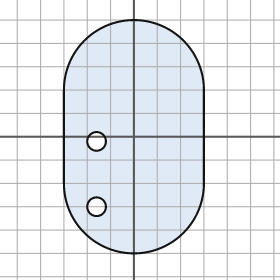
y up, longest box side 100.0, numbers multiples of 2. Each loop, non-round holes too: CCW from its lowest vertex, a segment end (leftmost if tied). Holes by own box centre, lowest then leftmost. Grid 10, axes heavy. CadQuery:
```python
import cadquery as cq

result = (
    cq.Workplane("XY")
    .moveTo(-30.0, -20.0)
    .threePointArc((0.0, -50.0), (30.0, -20.0))
    .lineTo(30.0, 20.0)
    .threePointArc((0.0, 50.0), (-30.0, 20.0))
    .close()
    .moveTo(-16.0, -30.0)
    .circle(4.0)
    .moveTo(-16.0, -2.0)
    .circle(4.0)
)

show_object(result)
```